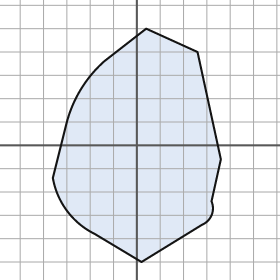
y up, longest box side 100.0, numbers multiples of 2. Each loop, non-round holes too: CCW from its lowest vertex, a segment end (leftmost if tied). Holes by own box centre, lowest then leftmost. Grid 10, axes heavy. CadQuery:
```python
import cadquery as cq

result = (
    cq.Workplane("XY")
    .moveTo(2.0, -50.0)
    .lineTo(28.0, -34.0)
    .threePointArc((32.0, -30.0), (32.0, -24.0))
    .lineTo(36.0, -6.0)
    .lineTo(26.0, 40.0)
    .lineTo(4.0, 50.0)
    .lineTo(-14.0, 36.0)
    .threePointArc((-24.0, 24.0), (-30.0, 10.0))
    .lineTo(-36.0, -14.0)
    .threePointArc((-30.0, -28.0), (-18.0, -38.0))
    .close()
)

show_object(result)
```